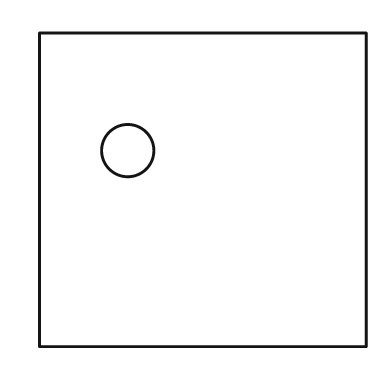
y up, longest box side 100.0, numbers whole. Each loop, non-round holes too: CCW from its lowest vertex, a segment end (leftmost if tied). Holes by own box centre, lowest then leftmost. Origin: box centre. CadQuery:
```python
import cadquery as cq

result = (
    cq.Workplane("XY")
    .moveTo(-50.0, -48.0)
    .lineTo(50.0, -48.0)
    .lineTo(50.0, 48.0)
    .lineTo(-50.0, 48.0)
    .close()
    .moveTo(-23.0, 12.0)
    .circle(8.0)
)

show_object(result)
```